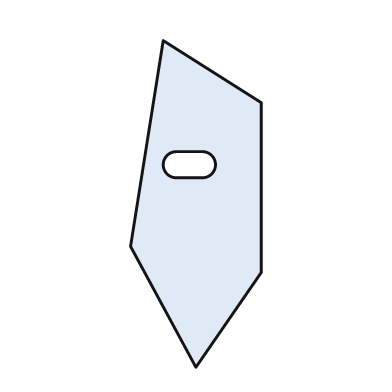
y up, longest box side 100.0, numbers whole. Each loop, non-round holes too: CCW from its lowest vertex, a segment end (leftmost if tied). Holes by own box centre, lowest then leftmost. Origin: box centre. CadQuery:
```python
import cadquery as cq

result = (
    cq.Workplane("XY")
    .moveTo(0.0, -50.0)
    .lineTo(20.0, -21.0)
    .lineTo(20.0, 31.0)
    .lineTo(-10.0, 50.0)
    .lineTo(-20.0, -13.0)
    .close()
    .moveTo(-6.0, 8.0)
    .lineTo(2.0, 8.0)
    .threePointArc((6.0, 12.0), (2.0, 16.0))
    .lineTo(-6.0, 16.0)
    .threePointArc((-10.0, 12.0), (-6.0, 8.0))
    .close()
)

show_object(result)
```